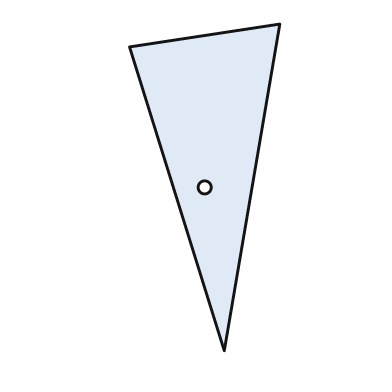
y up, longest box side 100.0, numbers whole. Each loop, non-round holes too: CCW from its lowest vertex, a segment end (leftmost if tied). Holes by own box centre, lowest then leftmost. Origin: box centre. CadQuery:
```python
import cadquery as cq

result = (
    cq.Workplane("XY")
    .moveTo(6.0, -50.0)
    .lineTo(23.0, 50.0)
    .lineTo(-23.0, 43.0)
    .close()
    .moveTo(0.0, 0.0)
    .circle(2.0)
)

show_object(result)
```